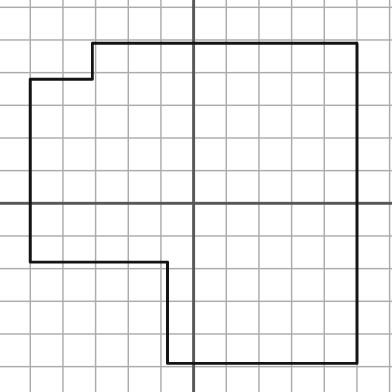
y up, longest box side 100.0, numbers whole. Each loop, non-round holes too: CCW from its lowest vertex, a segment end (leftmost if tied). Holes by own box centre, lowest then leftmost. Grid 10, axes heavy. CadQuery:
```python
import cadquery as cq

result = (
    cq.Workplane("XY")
    .moveTo(-8.0, -49.0)
    .lineTo(50.0, -49.0)
    .lineTo(50.0, 49.0)
    .lineTo(-31.0, 49.0)
    .lineTo(-31.0, 38.0)
    .lineTo(-50.0, 38.0)
    .lineTo(-50.0, -18.0)
    .lineTo(-8.0, -18.0)
    .close()
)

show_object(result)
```